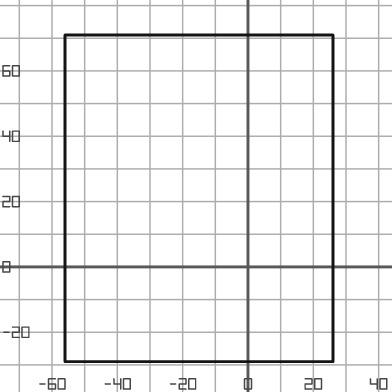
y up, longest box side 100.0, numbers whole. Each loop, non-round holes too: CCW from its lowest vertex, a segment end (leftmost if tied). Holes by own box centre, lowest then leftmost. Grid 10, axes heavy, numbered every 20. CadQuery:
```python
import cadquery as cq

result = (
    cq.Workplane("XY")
    .moveTo(-56.0, -29.0)
    .lineTo(26.0, -29.0)
    .lineTo(26.0, 71.0)
    .lineTo(-56.0, 71.0)
    .close()
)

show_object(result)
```